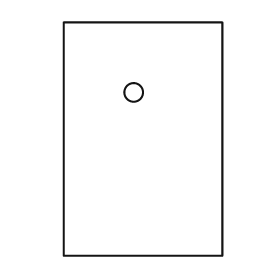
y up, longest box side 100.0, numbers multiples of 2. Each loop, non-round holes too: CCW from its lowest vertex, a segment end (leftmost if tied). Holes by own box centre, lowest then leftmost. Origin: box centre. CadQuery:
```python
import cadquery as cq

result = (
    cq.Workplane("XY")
    .moveTo(-34.0, -50.0)
    .lineTo(34.0, -50.0)
    .lineTo(34.0, 50.0)
    .lineTo(-34.0, 50.0)
    .close()
    .moveTo(-4.0, 20.0)
    .circle(4.0)
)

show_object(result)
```